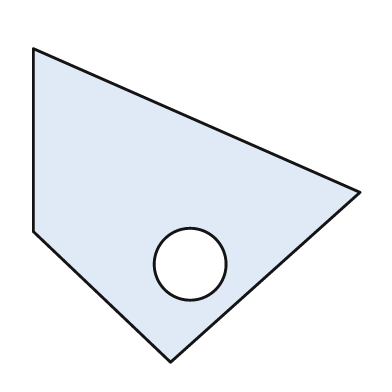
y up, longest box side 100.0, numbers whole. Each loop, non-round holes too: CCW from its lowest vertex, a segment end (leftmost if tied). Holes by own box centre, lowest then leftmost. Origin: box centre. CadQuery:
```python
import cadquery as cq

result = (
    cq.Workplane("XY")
    .moveTo(-8.0, -48.0)
    .lineTo(50.0, 4.0)
    .lineTo(-50.0, 48.0)
    .lineTo(-50.0, -8.0)
    .close()
    .moveTo(-2.0, -18.0)
    .circle(11.0)
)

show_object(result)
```